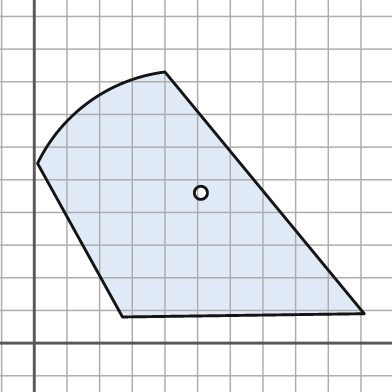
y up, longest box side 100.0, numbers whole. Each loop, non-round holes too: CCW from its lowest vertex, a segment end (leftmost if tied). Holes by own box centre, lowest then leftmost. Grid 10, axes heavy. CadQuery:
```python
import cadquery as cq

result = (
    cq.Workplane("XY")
    .moveTo(27.0, 8.0)
    .lineTo(101.0, 9.0)
    .lineTo(40.0, 83.0)
    .threePointArc((17.0, 74.0), (1.0, 55.0))
    .close()
    .moveTo(51.0, 46.0)
    .circle(2.0)
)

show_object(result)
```